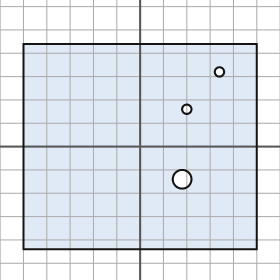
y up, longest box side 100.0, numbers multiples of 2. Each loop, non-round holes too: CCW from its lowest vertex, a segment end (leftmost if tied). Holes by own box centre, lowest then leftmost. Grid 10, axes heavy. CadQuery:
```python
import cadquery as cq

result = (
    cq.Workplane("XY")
    .moveTo(-50.0, -44.0)
    .lineTo(50.0, -44.0)
    .lineTo(50.0, 44.0)
    .lineTo(-50.0, 44.0)
    .close()
    .moveTo(18.0, -14.0)
    .circle(4.0)
    .moveTo(20.0, 16.0)
    .circle(2.0)
    .moveTo(34.0, 32.0)
    .circle(2.0)
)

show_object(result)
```